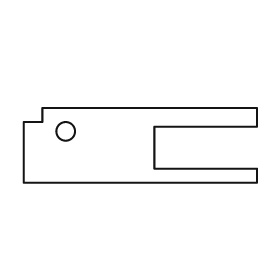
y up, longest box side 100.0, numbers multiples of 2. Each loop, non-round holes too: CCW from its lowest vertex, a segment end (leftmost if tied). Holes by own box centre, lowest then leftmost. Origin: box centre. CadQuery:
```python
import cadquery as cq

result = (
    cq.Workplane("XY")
    .moveTo(-50.0, -16.0)
    .lineTo(50.0, -16.0)
    .lineTo(50.0, -10.0)
    .lineTo(6.0, -10.0)
    .lineTo(6.0, 8.0)
    .lineTo(50.0, 8.0)
    .lineTo(50.0, 16.0)
    .lineTo(-42.0, 16.0)
    .lineTo(-42.0, 10.0)
    .lineTo(-50.0, 10.0)
    .close()
    .moveTo(-32.0, 6.0)
    .circle(4.0)
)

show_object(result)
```